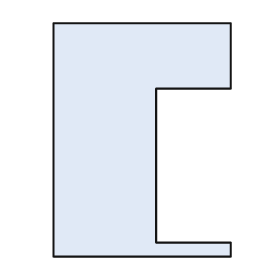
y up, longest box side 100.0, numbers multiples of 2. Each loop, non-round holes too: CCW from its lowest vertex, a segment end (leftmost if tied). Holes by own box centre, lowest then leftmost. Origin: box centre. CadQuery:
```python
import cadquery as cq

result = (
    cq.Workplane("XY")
    .moveTo(-38.0, -50.0)
    .lineTo(38.0, -50.0)
    .lineTo(38.0, -44.0)
    .lineTo(6.0, -44.0)
    .lineTo(6.0, 22.0)
    .lineTo(38.0, 22.0)
    .lineTo(38.0, 50.0)
    .lineTo(-38.0, 50.0)
    .close()
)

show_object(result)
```